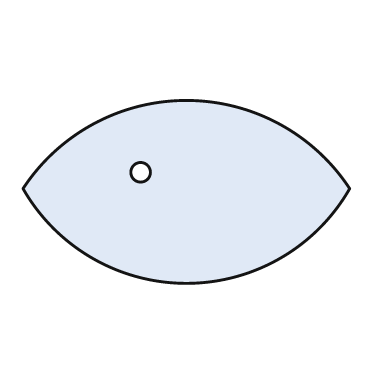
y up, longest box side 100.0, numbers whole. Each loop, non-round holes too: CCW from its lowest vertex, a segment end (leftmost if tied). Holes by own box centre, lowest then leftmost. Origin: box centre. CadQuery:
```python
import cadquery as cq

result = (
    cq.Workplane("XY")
    .moveTo(-50.0, 1.0)
    .threePointArc((0.0, -28.0), (50.0, 1.0))
    .threePointArc((0.0, 28.0), (-50.0, 1.0))
    .close()
    .moveTo(-14.0, 6.0)
    .circle(3.0)
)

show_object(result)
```